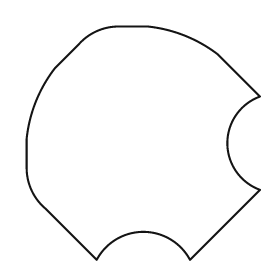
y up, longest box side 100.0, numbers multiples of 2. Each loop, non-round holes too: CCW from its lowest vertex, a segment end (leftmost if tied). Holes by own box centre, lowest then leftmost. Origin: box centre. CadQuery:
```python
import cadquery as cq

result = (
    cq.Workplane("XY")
    .moveTo(-20.0, -50.0)
    .threePointArc((0.0, -38.0), (20.0, -50.0))
    .lineTo(50.0, -20.0)
    .threePointArc((36.0, 0.0), (50.0, 20.0))
    .lineTo(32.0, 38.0)
    .threePointArc((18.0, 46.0), (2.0, 50.0))
    .lineTo(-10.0, 50.0)
    .threePointArc((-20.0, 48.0), (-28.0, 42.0))
    .lineTo(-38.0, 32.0)
    .threePointArc((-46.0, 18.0), (-50.0, 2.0))
    .lineTo(-50.0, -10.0)
    .threePointArc((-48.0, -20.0), (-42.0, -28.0))
    .close()
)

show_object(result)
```